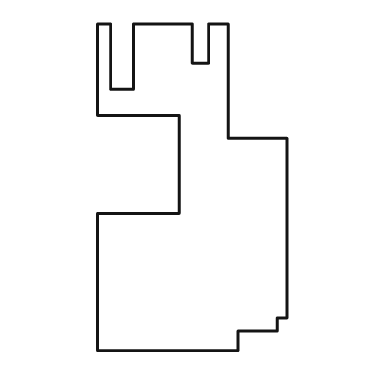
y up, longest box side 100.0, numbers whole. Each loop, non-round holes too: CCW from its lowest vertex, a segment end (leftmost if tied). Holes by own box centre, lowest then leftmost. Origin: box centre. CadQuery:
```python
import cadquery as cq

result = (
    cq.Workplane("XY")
    .moveTo(-29.0, -50.0)
    .lineTo(14.0, -50.0)
    .lineTo(14.0, -44.0)
    .lineTo(26.0, -44.0)
    .lineTo(26.0, -40.0)
    .lineTo(29.0, -40.0)
    .lineTo(29.0, 15.0)
    .lineTo(11.0, 15.0)
    .lineTo(11.0, 50.0)
    .lineTo(5.0, 50.0)
    .lineTo(5.0, 38.0)
    .lineTo(0.0, 38.0)
    .lineTo(0.0, 50.0)
    .lineTo(-18.0, 50.0)
    .lineTo(-18.0, 30.0)
    .lineTo(-25.0, 30.0)
    .lineTo(-25.0, 50.0)
    .lineTo(-29.0, 50.0)
    .lineTo(-29.0, 22.0)
    .lineTo(-4.0, 22.0)
    .lineTo(-4.0, -8.0)
    .lineTo(-29.0, -8.0)
    .close()
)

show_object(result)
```